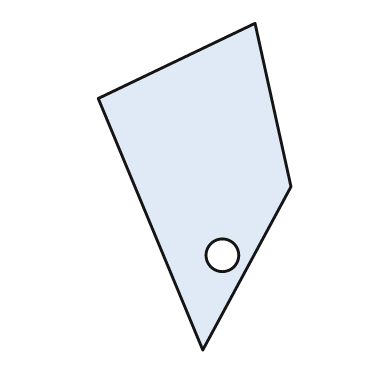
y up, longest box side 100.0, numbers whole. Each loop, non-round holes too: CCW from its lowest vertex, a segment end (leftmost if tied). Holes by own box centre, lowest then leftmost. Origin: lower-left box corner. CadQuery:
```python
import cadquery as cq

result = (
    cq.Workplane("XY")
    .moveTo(32.0, 0.0)
    .lineTo(59.0, 50.0)
    .lineTo(48.0, 100.0)
    .lineTo(0.0, 77.0)
    .close()
    .moveTo(38.0, 29.0)
    .circle(5.0)
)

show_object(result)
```